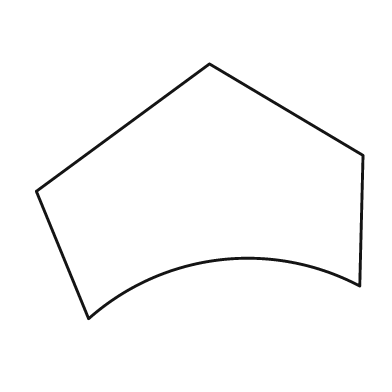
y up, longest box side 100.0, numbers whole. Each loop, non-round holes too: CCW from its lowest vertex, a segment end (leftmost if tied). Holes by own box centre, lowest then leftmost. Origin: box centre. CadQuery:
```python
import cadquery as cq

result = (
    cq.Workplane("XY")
    .moveTo(-34.0, -39.0)
    .threePointArc((6.0, -21.0), (49.0, -29.0))
    .lineTo(50.0, 11.0)
    .lineTo(3.0, 39.0)
    .lineTo(-50.0, 0.0)
    .close()
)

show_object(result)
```